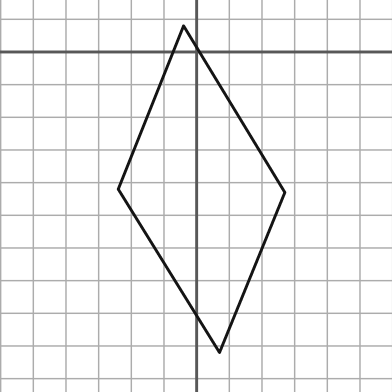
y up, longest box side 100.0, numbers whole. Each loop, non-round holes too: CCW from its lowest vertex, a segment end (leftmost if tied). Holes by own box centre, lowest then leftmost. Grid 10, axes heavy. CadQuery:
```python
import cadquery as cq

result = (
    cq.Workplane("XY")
    .moveTo(7.0, -92.0)
    .lineTo(27.0, -43.0)
    .lineTo(-4.0, 8.0)
    .lineTo(-24.0, -42.0)
    .close()
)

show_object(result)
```